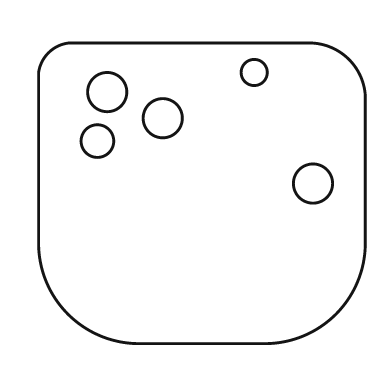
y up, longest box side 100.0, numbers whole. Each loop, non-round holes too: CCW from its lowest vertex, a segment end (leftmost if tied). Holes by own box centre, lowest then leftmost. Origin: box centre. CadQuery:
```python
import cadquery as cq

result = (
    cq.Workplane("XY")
    .moveTo(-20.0, -46.0)
    .lineTo(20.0, -46.0)
    .threePointArc((41.0, -37.0), (50.0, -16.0))
    .lineTo(50.0, 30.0)
    .threePointArc((45.0, 41.0), (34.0, 46.0))
    .lineTo(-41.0, 46.0)
    .threePointArc((-47.0, 43.0), (-50.0, 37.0))
    .lineTo(-50.0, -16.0)
    .threePointArc((-41.0, -37.0), (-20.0, -46.0))
    .close()
    .moveTo(34.0, 3.0)
    .circle(6.0)
    .moveTo(-32.0, 16.0)
    .circle(5.0)
    .moveTo(-12.0, 23.0)
    .circle(6.0)
    .moveTo(-29.0, 31.0)
    .circle(6.0)
    .moveTo(16.0, 37.0)
    .circle(4.0)
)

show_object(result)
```